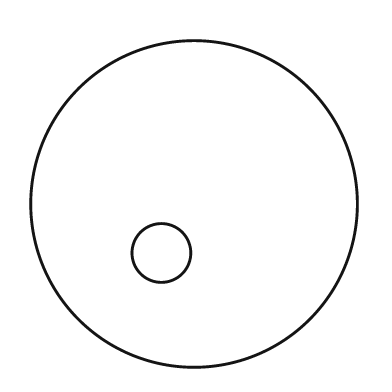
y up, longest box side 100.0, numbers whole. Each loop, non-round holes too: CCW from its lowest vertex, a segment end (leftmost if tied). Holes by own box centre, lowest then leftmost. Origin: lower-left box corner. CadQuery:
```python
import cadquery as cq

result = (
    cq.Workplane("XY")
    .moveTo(50.0, 50.0)
    .circle(50.0)
    .moveTo(40.0, 35.0)
    .circle(9.0)
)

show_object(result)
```